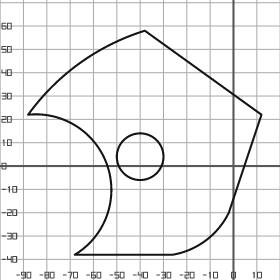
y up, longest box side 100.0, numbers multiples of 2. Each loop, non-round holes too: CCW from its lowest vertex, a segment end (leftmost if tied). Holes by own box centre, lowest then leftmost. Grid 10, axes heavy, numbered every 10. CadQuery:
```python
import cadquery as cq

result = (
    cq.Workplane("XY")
    .moveTo(-68.0, -38.0)
    .lineTo(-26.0, -38.0)
    .threePointArc((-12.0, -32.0), (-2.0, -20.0))
    .lineTo(12.0, 22.0)
    .lineTo(-38.0, 58.0)
    .threePointArc((-66.0, 44.0), (-88.0, 22.0))
    .threePointArc((-54.0, 0.0), (-68.0, -38.0))
    .close()
    .moveTo(-40.0, 4.0)
    .circle(10.0)
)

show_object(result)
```